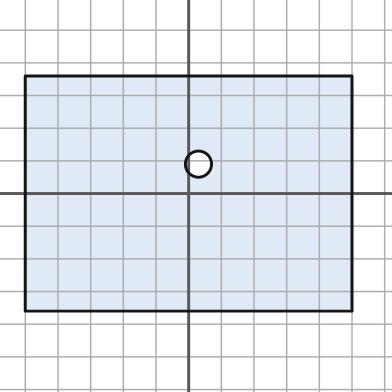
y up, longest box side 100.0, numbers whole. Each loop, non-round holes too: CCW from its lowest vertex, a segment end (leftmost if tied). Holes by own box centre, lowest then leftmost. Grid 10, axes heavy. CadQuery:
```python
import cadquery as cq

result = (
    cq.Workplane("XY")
    .moveTo(-50.0, -36.0)
    .lineTo(50.0, -36.0)
    .lineTo(50.0, 36.0)
    .lineTo(-50.0, 36.0)
    .close()
    .moveTo(3.0, 9.0)
    .circle(4.0)
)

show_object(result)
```